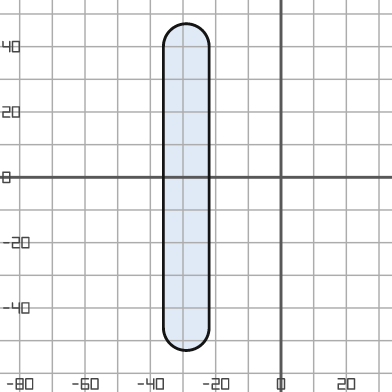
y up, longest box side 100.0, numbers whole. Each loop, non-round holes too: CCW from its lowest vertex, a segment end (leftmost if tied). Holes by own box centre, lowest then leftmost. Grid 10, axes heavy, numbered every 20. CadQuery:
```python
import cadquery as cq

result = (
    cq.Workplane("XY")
    .moveTo(-36.0, -46.0)
    .threePointArc((-29.0, -53.0), (-22.0, -46.0))
    .lineTo(-22.0, 40.0)
    .threePointArc((-29.0, 47.0), (-36.0, 40.0))
    .close()
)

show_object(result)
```